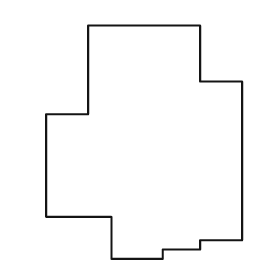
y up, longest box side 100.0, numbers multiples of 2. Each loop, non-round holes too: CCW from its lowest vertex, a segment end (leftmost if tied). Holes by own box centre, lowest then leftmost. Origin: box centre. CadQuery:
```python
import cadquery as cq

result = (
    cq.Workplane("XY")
    .moveTo(-14.0, -50.0)
    .lineTo(8.0, -50.0)
    .lineTo(8.0, -46.0)
    .lineTo(24.0, -46.0)
    .lineTo(24.0, -42.0)
    .lineTo(42.0, -42.0)
    .lineTo(42.0, 26.0)
    .lineTo(24.0, 26.0)
    .lineTo(24.0, 50.0)
    .lineTo(-24.0, 50.0)
    .lineTo(-24.0, 12.0)
    .lineTo(-42.0, 12.0)
    .lineTo(-42.0, -32.0)
    .lineTo(-14.0, -32.0)
    .close()
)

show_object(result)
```